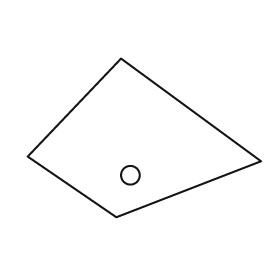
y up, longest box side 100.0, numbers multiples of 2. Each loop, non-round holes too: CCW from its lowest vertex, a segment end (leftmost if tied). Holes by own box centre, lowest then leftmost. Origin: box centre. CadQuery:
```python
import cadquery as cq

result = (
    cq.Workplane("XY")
    .moveTo(-12.0, -34.0)
    .lineTo(50.0, -10.0)
    .lineTo(-10.0, 34.0)
    .lineTo(-50.0, -8.0)
    .close()
    .moveTo(-6.0, -16.0)
    .circle(4.0)
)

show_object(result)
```